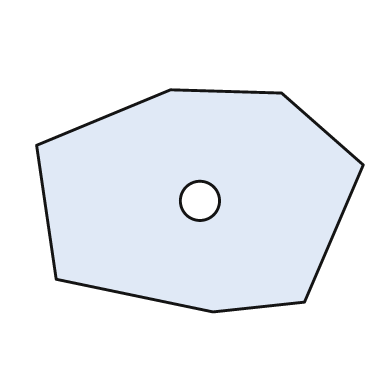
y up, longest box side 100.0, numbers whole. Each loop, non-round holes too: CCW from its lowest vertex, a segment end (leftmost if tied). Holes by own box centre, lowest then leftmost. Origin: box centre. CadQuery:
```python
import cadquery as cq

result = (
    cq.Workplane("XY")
    .moveTo(4.0, -34.0)
    .lineTo(32.0, -31.0)
    .lineTo(50.0, 11.0)
    .lineTo(25.0, 33.0)
    .lineTo(-9.0, 34.0)
    .lineTo(-50.0, 17.0)
    .lineTo(-44.0, -24.0)
    .close()
    .moveTo(0.0, 0.0)
    .circle(6.0)
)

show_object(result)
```